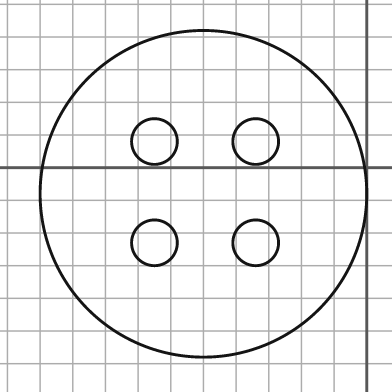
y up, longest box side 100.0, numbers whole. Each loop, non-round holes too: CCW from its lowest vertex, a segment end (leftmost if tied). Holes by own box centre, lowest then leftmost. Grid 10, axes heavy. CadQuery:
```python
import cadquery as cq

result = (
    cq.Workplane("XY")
    .moveTo(-50.0, -8.0)
    .circle(50.0)
    .moveTo(-65.0, -23.0)
    .circle(7.0)
    .moveTo(-34.0, -23.0)
    .circle(7.0)
    .moveTo(-65.0, 8.0)
    .circle(7.0)
    .moveTo(-34.0, 8.0)
    .circle(7.0)
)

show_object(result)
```